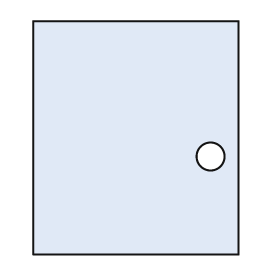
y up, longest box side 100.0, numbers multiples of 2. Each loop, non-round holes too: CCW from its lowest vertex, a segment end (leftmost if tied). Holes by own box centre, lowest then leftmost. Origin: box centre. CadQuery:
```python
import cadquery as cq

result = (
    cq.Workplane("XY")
    .moveTo(-44.0, -50.0)
    .lineTo(44.0, -50.0)
    .lineTo(44.0, 50.0)
    .lineTo(-44.0, 50.0)
    .close()
    .moveTo(32.0, -8.0)
    .circle(6.0)
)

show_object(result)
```